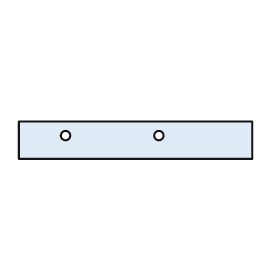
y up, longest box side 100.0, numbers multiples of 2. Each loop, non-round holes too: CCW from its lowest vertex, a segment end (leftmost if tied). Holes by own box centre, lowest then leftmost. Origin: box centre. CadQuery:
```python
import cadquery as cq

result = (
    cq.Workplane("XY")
    .moveTo(-50.0, -8.0)
    .lineTo(50.0, -8.0)
    .lineTo(50.0, 8.0)
    .lineTo(-50.0, 8.0)
    .close()
    .moveTo(-30.0, 2.0)
    .circle(2.0)
    .moveTo(10.0, 2.0)
    .circle(2.0)
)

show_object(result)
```